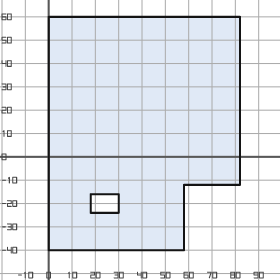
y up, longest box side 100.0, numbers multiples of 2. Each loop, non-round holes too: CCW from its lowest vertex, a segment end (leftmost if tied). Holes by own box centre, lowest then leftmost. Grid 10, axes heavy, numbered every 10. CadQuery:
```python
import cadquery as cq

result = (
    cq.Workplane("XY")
    .moveTo(0.0, -40.0)
    .lineTo(58.0, -40.0)
    .lineTo(58.0, -12.0)
    .lineTo(82.0, -12.0)
    .lineTo(82.0, 60.0)
    .lineTo(0.0, 60.0)
    .close()
    .moveTo(18.0, -24.0)
    .lineTo(30.0, -24.0)
    .lineTo(30.0, -16.0)
    .lineTo(18.0, -16.0)
    .close()
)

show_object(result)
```